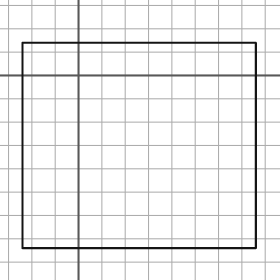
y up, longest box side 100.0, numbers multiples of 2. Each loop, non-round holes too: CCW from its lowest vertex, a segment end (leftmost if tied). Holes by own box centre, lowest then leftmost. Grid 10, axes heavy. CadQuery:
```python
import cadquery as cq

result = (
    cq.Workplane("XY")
    .moveTo(-24.0, -74.0)
    .lineTo(76.0, -74.0)
    .lineTo(76.0, 14.0)
    .lineTo(-24.0, 14.0)
    .close()
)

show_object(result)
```